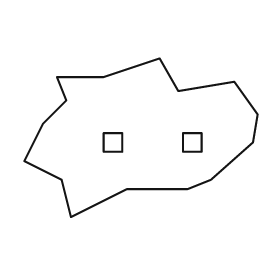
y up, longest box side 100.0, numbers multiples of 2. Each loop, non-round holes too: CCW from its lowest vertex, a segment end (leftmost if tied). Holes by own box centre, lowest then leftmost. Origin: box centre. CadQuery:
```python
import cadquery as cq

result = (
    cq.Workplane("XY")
    .moveTo(-30.0, -34.0)
    .lineTo(-6.0, -22.0)
    .lineTo(20.0, -22.0)
    .lineTo(30.0, -18.0)
    .lineTo(48.0, -2.0)
    .lineTo(50.0, 10.0)
    .lineTo(40.0, 24.0)
    .lineTo(16.0, 20.0)
    .lineTo(8.0, 34.0)
    .lineTo(-16.0, 26.0)
    .lineTo(-36.0, 26.0)
    .lineTo(-32.0, 16.0)
    .lineTo(-42.0, 6.0)
    .lineTo(-50.0, -10.0)
    .lineTo(-34.0, -18.0)
    .close()
    .moveTo(-16.0, -6.0)
    .lineTo(-8.0, -6.0)
    .lineTo(-8.0, 2.0)
    .lineTo(-16.0, 2.0)
    .close()
    .moveTo(18.0, -6.0)
    .lineTo(26.0, -6.0)
    .lineTo(26.0, 2.0)
    .lineTo(18.0, 2.0)
    .close()
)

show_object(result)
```